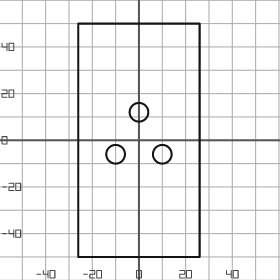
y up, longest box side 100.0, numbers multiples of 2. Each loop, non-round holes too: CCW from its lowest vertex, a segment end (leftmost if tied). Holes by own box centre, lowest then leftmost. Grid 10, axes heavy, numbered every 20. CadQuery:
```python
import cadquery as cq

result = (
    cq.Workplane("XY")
    .moveTo(-26.0, -50.0)
    .lineTo(26.0, -50.0)
    .lineTo(26.0, 50.0)
    .lineTo(-26.0, 50.0)
    .close()
    .moveTo(-10.0, -6.0)
    .circle(4.0)
    .moveTo(10.0, -6.0)
    .circle(4.0)
    .moveTo(0.0, 12.0)
    .circle(4.0)
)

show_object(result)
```